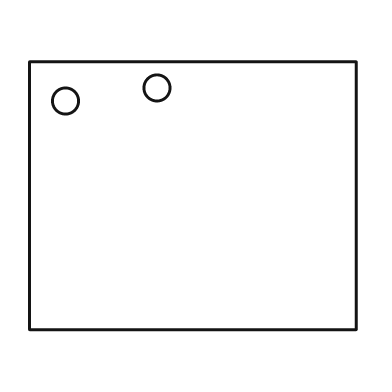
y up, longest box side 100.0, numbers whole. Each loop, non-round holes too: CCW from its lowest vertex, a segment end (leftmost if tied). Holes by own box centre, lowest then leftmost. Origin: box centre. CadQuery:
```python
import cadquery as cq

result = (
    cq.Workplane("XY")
    .moveTo(-50.0, -41.0)
    .lineTo(50.0, -41.0)
    .lineTo(50.0, 41.0)
    .lineTo(-50.0, 41.0)
    .close()
    .moveTo(-39.0, 29.0)
    .circle(4.0)
    .moveTo(-11.0, 33.0)
    .circle(4.0)
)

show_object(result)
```